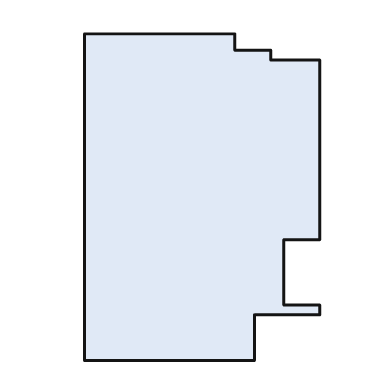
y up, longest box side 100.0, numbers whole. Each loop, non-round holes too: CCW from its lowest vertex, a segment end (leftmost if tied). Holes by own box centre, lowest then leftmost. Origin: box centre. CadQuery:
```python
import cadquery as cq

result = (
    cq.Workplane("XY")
    .moveTo(-36.0, -50.0)
    .lineTo(16.0, -50.0)
    .lineTo(16.0, -36.0)
    .lineTo(36.0, -36.0)
    .lineTo(36.0, -33.0)
    .lineTo(25.0, -33.0)
    .lineTo(25.0, -13.0)
    .lineTo(36.0, -13.0)
    .lineTo(36.0, 42.0)
    .lineTo(21.0, 42.0)
    .lineTo(21.0, 45.0)
    .lineTo(10.0, 45.0)
    .lineTo(10.0, 50.0)
    .lineTo(-36.0, 50.0)
    .close()
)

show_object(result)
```